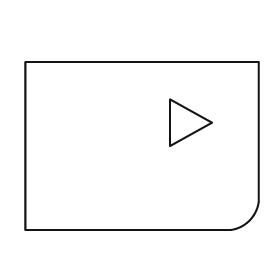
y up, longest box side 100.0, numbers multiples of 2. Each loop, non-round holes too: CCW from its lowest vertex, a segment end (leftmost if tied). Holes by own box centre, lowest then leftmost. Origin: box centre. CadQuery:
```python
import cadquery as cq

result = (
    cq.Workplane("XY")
    .moveTo(-50.0, -36.0)
    .lineTo(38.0, -36.0)
    .threePointArc((46.0, -32.0), (50.0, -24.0))
    .lineTo(50.0, 36.0)
    .lineTo(-50.0, 36.0)
    .close()
    .moveTo(12.0, 0.0)
    .lineTo(30.0, 10.0)
    .lineTo(12.0, 20.0)
    .close()
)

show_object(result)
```